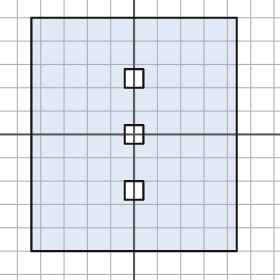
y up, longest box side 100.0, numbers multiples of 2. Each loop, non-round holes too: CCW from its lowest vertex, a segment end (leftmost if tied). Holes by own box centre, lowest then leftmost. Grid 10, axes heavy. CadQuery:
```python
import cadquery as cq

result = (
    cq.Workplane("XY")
    .moveTo(-44.0, -50.0)
    .lineTo(44.0, -50.0)
    .lineTo(44.0, 50.0)
    .lineTo(-44.0, 50.0)
    .close()
    .moveTo(-4.0, -28.0)
    .lineTo(4.0, -28.0)
    .lineTo(4.0, -20.0)
    .lineTo(-4.0, -20.0)
    .close()
    .moveTo(-4.0, -4.0)
    .lineTo(4.0, -4.0)
    .lineTo(4.0, 4.0)
    .lineTo(-4.0, 4.0)
    .close()
    .moveTo(-4.0, 20.0)
    .lineTo(4.0, 20.0)
    .lineTo(4.0, 28.0)
    .lineTo(-4.0, 28.0)
    .close()
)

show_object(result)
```